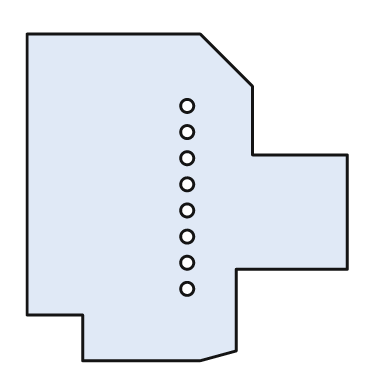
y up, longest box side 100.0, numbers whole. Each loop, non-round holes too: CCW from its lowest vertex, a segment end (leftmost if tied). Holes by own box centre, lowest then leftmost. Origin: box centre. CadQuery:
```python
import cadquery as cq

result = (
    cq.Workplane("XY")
    .moveTo(-32.0, -50.0)
    .lineTo(4.0, -50.0)
    .lineTo(15.0, -47.0)
    .lineTo(15.0, -22.0)
    .lineTo(49.0, -22.0)
    .lineTo(49.0, 13.0)
    .lineTo(20.0, 13.0)
    .lineTo(20.0, 34.0)
    .lineTo(4.0, 50.0)
    .lineTo(-49.0, 50.0)
    .lineTo(-49.0, -36.0)
    .lineTo(-32.0, -36.0)
    .close()
    .moveTo(0.0, -28.0)
    .circle(2.0)
    .moveTo(0.0, -20.0)
    .circle(2.0)
    .moveTo(0.0, -12.0)
    .circle(2.0)
    .moveTo(0.0, -4.0)
    .circle(2.0)
    .moveTo(0.0, 4.0)
    .circle(2.0)
    .moveTo(0.0, 12.0)
    .circle(2.0)
    .moveTo(0.0, 20.0)
    .circle(2.0)
    .moveTo(0.0, 28.0)
    .circle(2.0)
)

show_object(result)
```